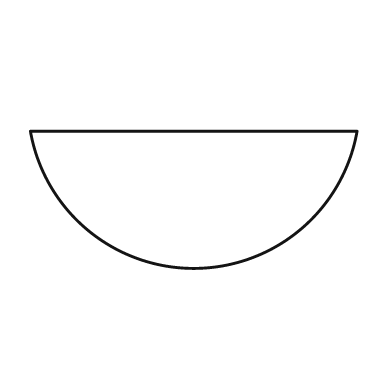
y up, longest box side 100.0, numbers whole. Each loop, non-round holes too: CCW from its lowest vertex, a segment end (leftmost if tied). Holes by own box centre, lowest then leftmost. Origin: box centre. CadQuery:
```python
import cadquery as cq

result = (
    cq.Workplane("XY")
    .moveTo(-50.0, 21.0)
    .threePointArc((0.0, -21.0), (50.0, 21.0))
    .close()
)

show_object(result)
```